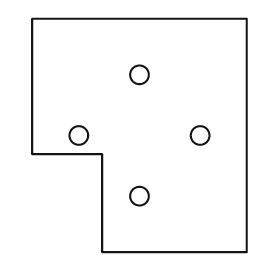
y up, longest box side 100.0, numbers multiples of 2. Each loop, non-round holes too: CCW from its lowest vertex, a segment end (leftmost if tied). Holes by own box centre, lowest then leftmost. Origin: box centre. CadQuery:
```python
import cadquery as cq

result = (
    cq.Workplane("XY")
    .moveTo(-16.0, -50.0)
    .lineTo(46.0, -50.0)
    .lineTo(46.0, 50.0)
    .lineTo(-46.0, 50.0)
    .lineTo(-46.0, -8.0)
    .lineTo(-16.0, -8.0)
    .close()
    .moveTo(0.0, -26.0)
    .circle(4.0)
    .moveTo(-26.0, 0.0)
    .circle(4.0)
    .moveTo(26.0, 0.0)
    .circle(4.0)
    .moveTo(0.0, 26.0)
    .circle(4.0)
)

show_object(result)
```